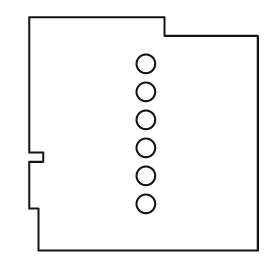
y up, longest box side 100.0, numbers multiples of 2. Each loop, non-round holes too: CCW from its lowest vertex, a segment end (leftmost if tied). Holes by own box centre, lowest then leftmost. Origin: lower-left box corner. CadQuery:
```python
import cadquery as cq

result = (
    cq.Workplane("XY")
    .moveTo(4.0, 0.0)
    .lineTo(98.0, 0.0)
    .lineTo(98.0, 92.0)
    .lineTo(58.0, 92.0)
    .lineTo(58.0, 100.0)
    .lineTo(0.0, 100.0)
    .lineTo(0.0, 42.0)
    .lineTo(6.0, 42.0)
    .lineTo(6.0, 38.0)
    .lineTo(0.0, 38.0)
    .lineTo(0.0, 18.0)
    .lineTo(4.0, 18.0)
    .close()
    .moveTo(50.0, 20.0)
    .circle(4.0)
    .moveTo(50.0, 32.0)
    .circle(4.0)
    .moveTo(50.0, 44.0)
    .circle(4.0)
    .moveTo(50.0, 56.0)
    .circle(4.0)
    .moveTo(50.0, 68.0)
    .circle(4.0)
    .moveTo(50.0, 80.0)
    .circle(4.0)
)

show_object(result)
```